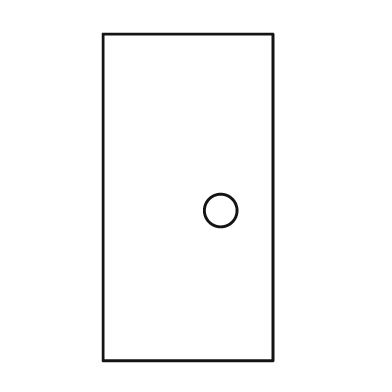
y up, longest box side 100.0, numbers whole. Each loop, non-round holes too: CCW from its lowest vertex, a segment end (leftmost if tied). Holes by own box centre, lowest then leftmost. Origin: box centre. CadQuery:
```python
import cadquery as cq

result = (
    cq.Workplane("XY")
    .moveTo(-26.0, -50.0)
    .lineTo(26.0, -50.0)
    .lineTo(26.0, 50.0)
    .lineTo(-26.0, 50.0)
    .close()
    .moveTo(10.0, -4.0)
    .circle(5.0)
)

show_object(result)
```